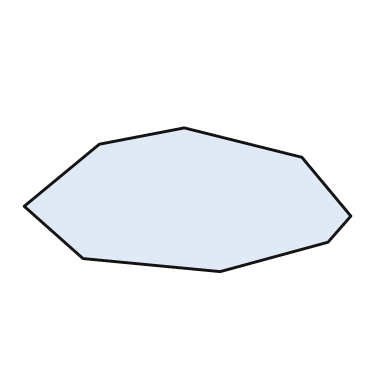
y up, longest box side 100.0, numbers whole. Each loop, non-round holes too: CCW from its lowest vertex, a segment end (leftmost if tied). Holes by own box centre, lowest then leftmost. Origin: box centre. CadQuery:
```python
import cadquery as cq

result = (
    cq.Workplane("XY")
    .moveTo(10.0, -22.0)
    .lineTo(43.0, -13.0)
    .lineTo(50.0, -5.0)
    .lineTo(35.0, 13.0)
    .lineTo(-1.0, 22.0)
    .lineTo(-27.0, 17.0)
    .lineTo(-50.0, -2.0)
    .lineTo(-32.0, -18.0)
    .close()
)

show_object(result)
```